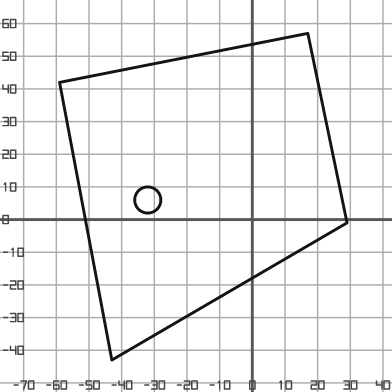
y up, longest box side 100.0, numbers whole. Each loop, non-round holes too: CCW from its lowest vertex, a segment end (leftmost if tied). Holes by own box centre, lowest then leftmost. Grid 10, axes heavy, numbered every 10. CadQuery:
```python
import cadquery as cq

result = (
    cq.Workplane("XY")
    .moveTo(-43.0, -43.0)
    .lineTo(29.0, -1.0)
    .lineTo(17.0, 57.0)
    .lineTo(-59.0, 42.0)
    .close()
    .moveTo(-32.0, 6.0)
    .circle(4.0)
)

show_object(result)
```